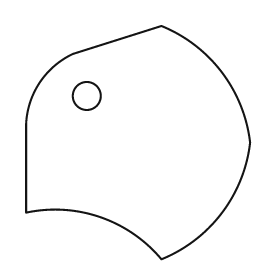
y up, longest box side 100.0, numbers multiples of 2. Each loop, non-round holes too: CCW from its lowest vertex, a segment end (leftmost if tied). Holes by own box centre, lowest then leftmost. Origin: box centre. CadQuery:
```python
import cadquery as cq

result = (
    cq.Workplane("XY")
    .moveTo(10.0, -50.0)
    .threePointArc((36.0, -30.0), (48.0, 0.0))
    .threePointArc((36.0, 30.0), (10.0, 50.0))
    .lineTo(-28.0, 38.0)
    .threePointArc((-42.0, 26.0), (-48.0, 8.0))
    .lineTo(-48.0, -30.0)
    .threePointArc((-16.0, -32.0), (10.0, -50.0))
    .close()
    .moveTo(-22.0, 20.0)
    .circle(6.0)
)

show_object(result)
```